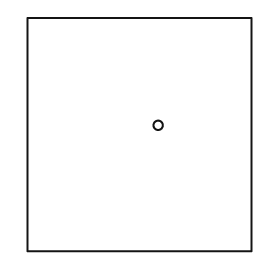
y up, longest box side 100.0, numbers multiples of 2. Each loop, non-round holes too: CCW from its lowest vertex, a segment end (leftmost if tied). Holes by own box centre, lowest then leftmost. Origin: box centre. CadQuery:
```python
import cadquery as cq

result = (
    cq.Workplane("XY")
    .moveTo(-48.0, -50.0)
    .lineTo(48.0, -50.0)
    .lineTo(48.0, 50.0)
    .lineTo(-48.0, 50.0)
    .close()
    .moveTo(8.0, 4.0)
    .circle(2.0)
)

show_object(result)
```